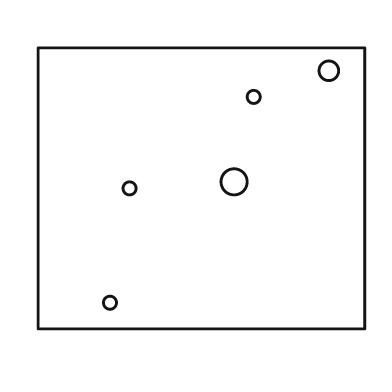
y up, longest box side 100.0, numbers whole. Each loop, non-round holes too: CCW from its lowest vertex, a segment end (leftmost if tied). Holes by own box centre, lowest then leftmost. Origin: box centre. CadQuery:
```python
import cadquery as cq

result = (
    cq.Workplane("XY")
    .moveTo(-50.0, -43.0)
    .lineTo(50.0, -43.0)
    .lineTo(50.0, 43.0)
    .lineTo(-50.0, 43.0)
    .close()
    .moveTo(-28.0, -35.0)
    .circle(2.0)
    .moveTo(-22.0, 0.0)
    .circle(2.0)
    .moveTo(10.0, 2.0)
    .circle(4.0)
    .moveTo(16.0, 28.0)
    .circle(2.0)
    .moveTo(39.0, 36.0)
    .circle(3.0)
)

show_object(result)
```